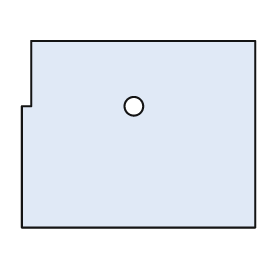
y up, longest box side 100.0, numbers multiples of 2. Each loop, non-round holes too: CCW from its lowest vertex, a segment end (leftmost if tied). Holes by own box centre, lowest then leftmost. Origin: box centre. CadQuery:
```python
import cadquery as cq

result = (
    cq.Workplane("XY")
    .moveTo(-50.0, -40.0)
    .lineTo(50.0, -40.0)
    .lineTo(50.0, 40.0)
    .lineTo(-46.0, 40.0)
    .lineTo(-46.0, 12.0)
    .lineTo(-50.0, 12.0)
    .close()
    .moveTo(-2.0, 12.0)
    .circle(4.0)
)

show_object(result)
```